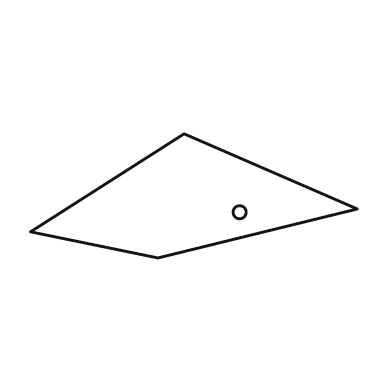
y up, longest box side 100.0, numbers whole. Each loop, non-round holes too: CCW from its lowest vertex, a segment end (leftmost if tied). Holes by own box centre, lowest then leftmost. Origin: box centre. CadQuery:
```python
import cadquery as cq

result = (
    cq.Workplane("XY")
    .moveTo(-11.0, -19.0)
    .lineTo(50.0, -4.0)
    .lineTo(-3.0, 19.0)
    .lineTo(-50.0, -11.0)
    .close()
    .moveTo(14.0, -5.0)
    .circle(2.0)
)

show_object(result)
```